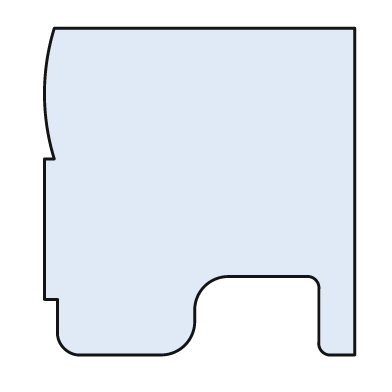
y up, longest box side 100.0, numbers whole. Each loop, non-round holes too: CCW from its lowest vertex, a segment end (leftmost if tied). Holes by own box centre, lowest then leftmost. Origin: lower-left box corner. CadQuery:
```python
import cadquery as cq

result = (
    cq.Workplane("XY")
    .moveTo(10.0, 0.0)
    .lineTo(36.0, 0.0)
    .threePointArc((43.0, 3.0), (46.0, 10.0))
    .lineTo(46.0, 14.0)
    .threePointArc((49.0, 21.0), (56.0, 24.0))
    .lineTo(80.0, 24.0)
    .threePointArc((83.0, 23.0), (84.0, 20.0))
    .lineTo(84.0, 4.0)
    .threePointArc((85.0, 1.0), (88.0, 0.0))
    .lineTo(95.0, 0.0)
    .lineTo(95.0, 100.0)
    .lineTo(3.0, 100.0)
    .threePointArc((0.0, 80.0), (3.0, 60.0))
    .lineTo(0.0, 60.0)
    .lineTo(0.0, 17.0)
    .lineTo(4.0, 17.0)
    .lineTo(4.0, 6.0)
    .threePointArc((6.0, 2.0), (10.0, 0.0))
    .close()
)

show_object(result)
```